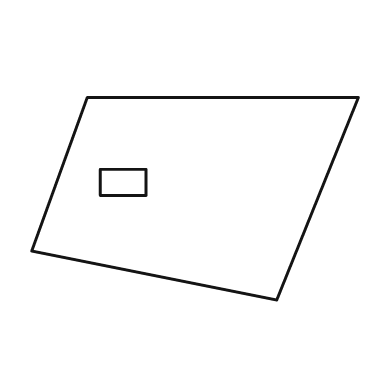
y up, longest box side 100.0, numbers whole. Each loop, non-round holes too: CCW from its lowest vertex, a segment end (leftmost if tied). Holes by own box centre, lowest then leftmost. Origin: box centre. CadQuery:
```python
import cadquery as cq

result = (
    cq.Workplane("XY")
    .moveTo(25.0, -31.0)
    .lineTo(50.0, 31.0)
    .lineTo(-33.0, 31.0)
    .lineTo(-50.0, -16.0)
    .close()
    .moveTo(-29.0, 1.0)
    .lineTo(-15.0, 1.0)
    .lineTo(-15.0, 9.0)
    .lineTo(-29.0, 9.0)
    .close()
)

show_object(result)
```